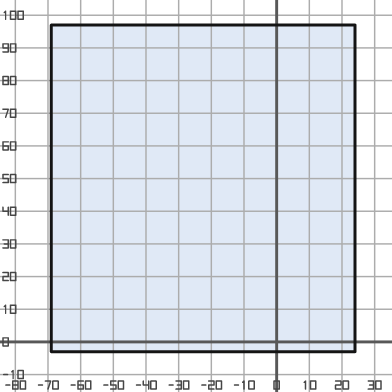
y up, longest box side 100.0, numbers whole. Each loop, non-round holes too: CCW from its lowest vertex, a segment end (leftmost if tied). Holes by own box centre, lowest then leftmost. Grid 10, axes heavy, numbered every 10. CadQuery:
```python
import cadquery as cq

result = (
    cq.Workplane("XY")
    .moveTo(-69.0, -3.0)
    .lineTo(24.0, -3.0)
    .lineTo(24.0, 97.0)
    .lineTo(-69.0, 97.0)
    .close()
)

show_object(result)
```